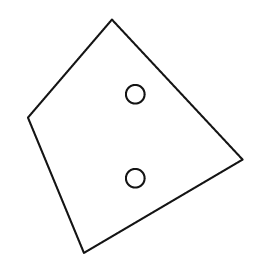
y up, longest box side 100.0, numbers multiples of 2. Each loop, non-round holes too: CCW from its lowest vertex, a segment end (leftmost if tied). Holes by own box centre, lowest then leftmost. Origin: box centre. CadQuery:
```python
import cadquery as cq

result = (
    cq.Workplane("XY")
    .moveTo(-22.0, -50.0)
    .lineTo(46.0, -10.0)
    .lineTo(-10.0, 50.0)
    .lineTo(-46.0, 8.0)
    .close()
    .moveTo(0.0, -18.0)
    .circle(4.0)
    .moveTo(0.0, 18.0)
    .circle(4.0)
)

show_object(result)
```